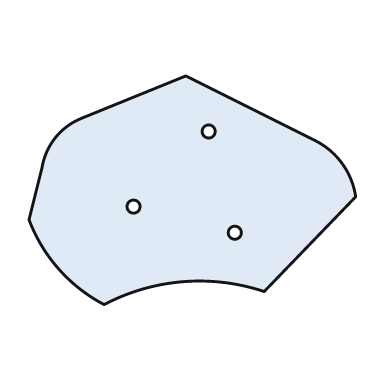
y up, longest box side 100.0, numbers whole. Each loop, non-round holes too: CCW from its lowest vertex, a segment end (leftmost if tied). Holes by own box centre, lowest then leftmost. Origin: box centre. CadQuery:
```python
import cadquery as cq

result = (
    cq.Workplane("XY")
    .moveTo(-27.0, -35.0)
    .threePointArc((-3.0, -28.0), (22.0, -31.0))
    .lineTo(50.0, -2.0)
    .threePointArc((46.0, 8.0), (38.0, 15.0))
    .lineTo(-2.0, 35.0)
    .lineTo(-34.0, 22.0)
    .threePointArc((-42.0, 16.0), (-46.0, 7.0))
    .lineTo(-50.0, -9.0)
    .threePointArc((-41.0, -24.0), (-27.0, -35.0))
    .close()
    .moveTo(13.0, -13.0)
    .circle(2.0)
    .moveTo(-18.0, -5.0)
    .circle(2.0)
    .moveTo(5.0, 18.0)
    .circle(2.0)
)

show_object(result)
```